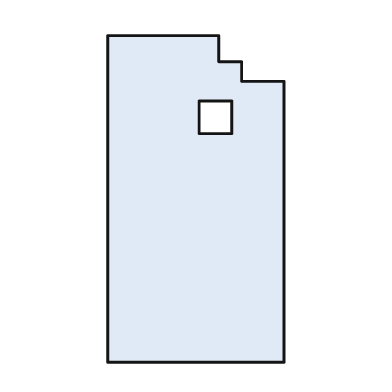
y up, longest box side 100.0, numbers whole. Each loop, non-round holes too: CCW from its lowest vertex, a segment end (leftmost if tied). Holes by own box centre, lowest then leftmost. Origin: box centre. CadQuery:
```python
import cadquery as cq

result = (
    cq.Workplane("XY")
    .moveTo(-27.0, -50.0)
    .lineTo(27.0, -50.0)
    .lineTo(27.0, 36.0)
    .lineTo(14.0, 36.0)
    .lineTo(14.0, 42.0)
    .lineTo(7.0, 42.0)
    .lineTo(7.0, 50.0)
    .lineTo(-27.0, 50.0)
    .close()
    .moveTo(1.0, 20.0)
    .lineTo(11.0, 20.0)
    .lineTo(11.0, 30.0)
    .lineTo(1.0, 30.0)
    .close()
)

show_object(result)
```